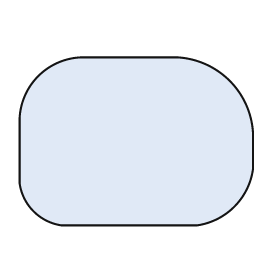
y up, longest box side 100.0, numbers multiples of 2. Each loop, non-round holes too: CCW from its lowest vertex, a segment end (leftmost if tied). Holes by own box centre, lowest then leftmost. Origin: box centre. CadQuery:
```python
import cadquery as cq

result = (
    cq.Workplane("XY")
    .moveTo(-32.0, -36.0)
    .lineTo(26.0, -36.0)
    .threePointArc((42.0, -28.0), (50.0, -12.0))
    .lineTo(50.0, 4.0)
    .threePointArc((40.0, 26.0), (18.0, 36.0))
    .lineTo(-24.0, 36.0)
    .threePointArc((-42.0, 28.0), (-50.0, 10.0))
    .lineTo(-50.0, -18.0)
    .threePointArc((-44.0, -30.0), (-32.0, -36.0))
    .close()
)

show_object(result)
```